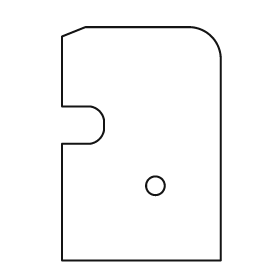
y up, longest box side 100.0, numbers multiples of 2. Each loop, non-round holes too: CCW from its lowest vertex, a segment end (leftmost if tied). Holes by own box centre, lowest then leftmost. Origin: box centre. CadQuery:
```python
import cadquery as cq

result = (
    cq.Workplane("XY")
    .moveTo(-34.0, -50.0)
    .lineTo(34.0, -50.0)
    .lineTo(34.0, 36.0)
    .threePointArc((30.0, 46.0), (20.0, 50.0))
    .lineTo(-24.0, 50.0)
    .lineTo(-34.0, 46.0)
    .lineTo(-34.0, 16.0)
    .lineTo(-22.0, 16.0)
    .threePointArc((-18.0, 14.0), (-16.0, 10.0))
    .lineTo(-16.0, 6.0)
    .threePointArc((-18.0, 2.0), (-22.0, 0.0))
    .lineTo(-34.0, 0.0)
    .close()
    .moveTo(6.0, -18.0)
    .circle(4.0)
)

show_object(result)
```